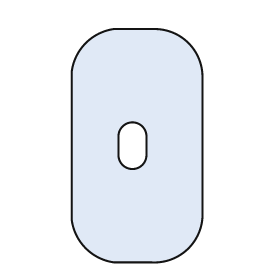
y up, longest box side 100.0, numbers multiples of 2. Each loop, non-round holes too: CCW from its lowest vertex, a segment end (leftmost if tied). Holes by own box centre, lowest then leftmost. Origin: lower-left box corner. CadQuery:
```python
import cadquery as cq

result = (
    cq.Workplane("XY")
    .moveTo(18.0, 0.0)
    .lineTo(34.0, 0.0)
    .threePointArc((50.0, 6.0), (56.0, 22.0))
    .lineTo(56.0, 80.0)
    .threePointArc((50.0, 94.0), (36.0, 100.0))
    .lineTo(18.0, 100.0)
    .threePointArc((6.0, 94.0), (0.0, 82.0))
    .lineTo(0.0, 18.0)
    .threePointArc((6.0, 6.0), (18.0, 0.0))
    .close()
    .moveTo(20.0, 46.0)
    .threePointArc((26.0, 40.0), (32.0, 46.0))
    .lineTo(32.0, 54.0)
    .threePointArc((26.0, 60.0), (20.0, 54.0))
    .close()
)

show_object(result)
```